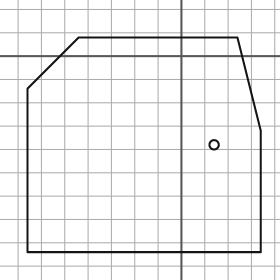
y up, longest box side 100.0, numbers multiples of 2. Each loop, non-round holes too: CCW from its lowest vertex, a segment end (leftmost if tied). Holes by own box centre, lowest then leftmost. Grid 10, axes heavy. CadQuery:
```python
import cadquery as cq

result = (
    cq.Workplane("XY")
    .moveTo(-66.0, -84.0)
    .lineTo(34.0, -84.0)
    .lineTo(34.0, -32.0)
    .lineTo(24.0, 8.0)
    .lineTo(-44.0, 8.0)
    .lineTo(-66.0, -14.0)
    .close()
    .moveTo(14.0, -38.0)
    .circle(2.0)
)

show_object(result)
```